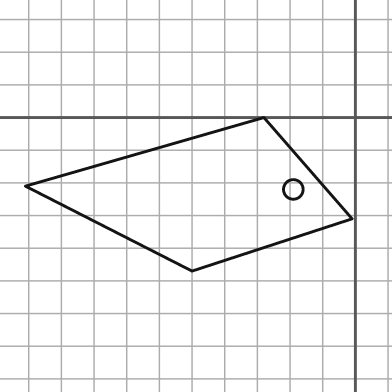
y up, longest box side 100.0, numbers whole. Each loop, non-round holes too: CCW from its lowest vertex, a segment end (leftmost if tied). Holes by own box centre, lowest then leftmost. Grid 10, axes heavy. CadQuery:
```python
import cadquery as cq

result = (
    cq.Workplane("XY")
    .moveTo(-50.0, -47.0)
    .lineTo(-1.0, -31.0)
    .lineTo(-28.0, 0.0)
    .lineTo(-101.0, -21.0)
    .close()
    .moveTo(-19.0, -22.0)
    .circle(3.0)
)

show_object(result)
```